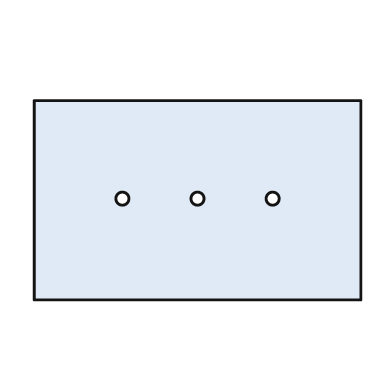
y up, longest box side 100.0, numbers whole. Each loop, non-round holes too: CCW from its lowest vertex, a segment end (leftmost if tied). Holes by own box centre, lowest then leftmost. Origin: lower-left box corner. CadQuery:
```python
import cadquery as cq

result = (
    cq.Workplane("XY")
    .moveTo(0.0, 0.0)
    .lineTo(100.0, 0.0)
    .lineTo(100.0, 61.0)
    .lineTo(0.0, 61.0)
    .close()
    .moveTo(27.0, 31.0)
    .circle(2.0)
    .moveTo(50.0, 31.0)
    .circle(2.0)
    .moveTo(73.0, 31.0)
    .circle(2.0)
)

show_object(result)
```